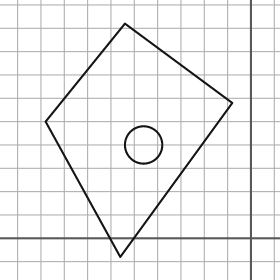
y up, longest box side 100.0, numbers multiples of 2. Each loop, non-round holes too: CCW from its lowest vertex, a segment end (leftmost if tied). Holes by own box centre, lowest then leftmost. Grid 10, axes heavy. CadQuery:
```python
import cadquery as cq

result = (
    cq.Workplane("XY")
    .moveTo(-56.0, -8.0)
    .lineTo(-8.0, 58.0)
    .lineTo(-54.0, 92.0)
    .lineTo(-88.0, 50.0)
    .close()
    .moveTo(-46.0, 40.0)
    .circle(8.0)
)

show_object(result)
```